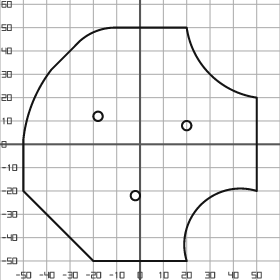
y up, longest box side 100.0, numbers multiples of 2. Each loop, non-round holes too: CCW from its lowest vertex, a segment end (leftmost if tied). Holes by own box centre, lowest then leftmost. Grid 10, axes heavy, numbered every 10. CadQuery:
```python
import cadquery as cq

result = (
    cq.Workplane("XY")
    .moveTo(-20.0, -50.0)
    .lineTo(20.0, -50.0)
    .threePointArc((26.0, -26.0), (50.0, -20.0))
    .lineTo(50.0, 20.0)
    .threePointArc((30.0, 30.0), (20.0, 50.0))
    .lineTo(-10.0, 50.0)
    .threePointArc((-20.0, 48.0), (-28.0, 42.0))
    .lineTo(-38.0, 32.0)
    .threePointArc((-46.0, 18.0), (-50.0, 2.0))
    .lineTo(-50.0, -20.0)
    .close()
    .moveTo(-2.0, -22.0)
    .circle(2.0)
    .moveTo(20.0, 8.0)
    .circle(2.0)
    .moveTo(-18.0, 12.0)
    .circle(2.0)
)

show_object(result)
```